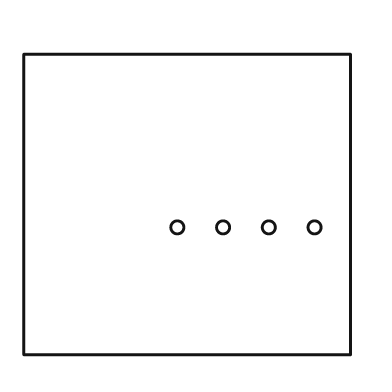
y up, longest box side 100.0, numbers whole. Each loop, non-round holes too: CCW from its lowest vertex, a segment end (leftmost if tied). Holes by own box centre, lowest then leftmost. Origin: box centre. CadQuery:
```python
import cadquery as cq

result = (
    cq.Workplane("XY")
    .moveTo(-50.0, -46.0)
    .lineTo(50.0, -46.0)
    .lineTo(50.0, 46.0)
    .lineTo(-50.0, 46.0)
    .close()
    .moveTo(-3.0, -7.0)
    .circle(2.0)
    .moveTo(11.0, -7.0)
    .circle(2.0)
    .moveTo(25.0, -7.0)
    .circle(2.0)
    .moveTo(39.0, -7.0)
    .circle(2.0)
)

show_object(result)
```